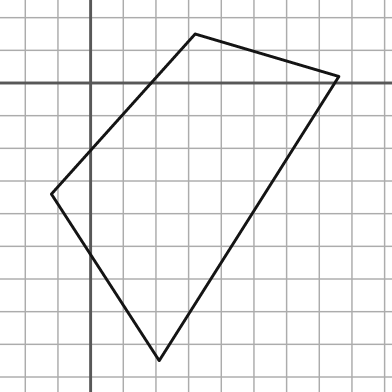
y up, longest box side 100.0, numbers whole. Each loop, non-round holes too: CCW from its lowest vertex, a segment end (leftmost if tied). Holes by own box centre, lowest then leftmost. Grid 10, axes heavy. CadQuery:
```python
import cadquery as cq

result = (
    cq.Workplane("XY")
    .moveTo(21.0, -85.0)
    .lineTo(76.0, 2.0)
    .lineTo(32.0, 15.0)
    .lineTo(-12.0, -34.0)
    .close()
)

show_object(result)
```